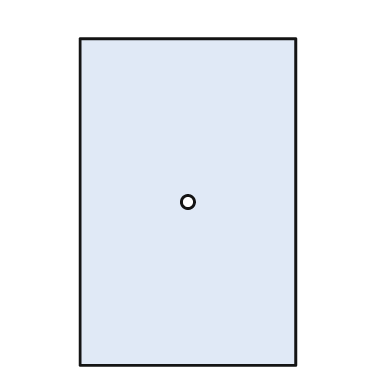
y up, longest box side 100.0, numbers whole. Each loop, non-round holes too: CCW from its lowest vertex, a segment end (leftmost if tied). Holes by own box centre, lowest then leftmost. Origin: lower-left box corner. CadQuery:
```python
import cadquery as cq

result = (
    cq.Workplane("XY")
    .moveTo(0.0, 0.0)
    .lineTo(66.0, 0.0)
    .lineTo(66.0, 100.0)
    .lineTo(0.0, 100.0)
    .close()
    .moveTo(33.0, 50.0)
    .circle(2.0)
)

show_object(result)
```